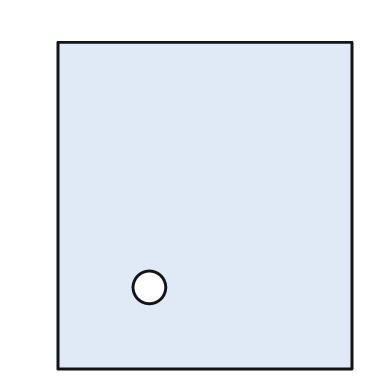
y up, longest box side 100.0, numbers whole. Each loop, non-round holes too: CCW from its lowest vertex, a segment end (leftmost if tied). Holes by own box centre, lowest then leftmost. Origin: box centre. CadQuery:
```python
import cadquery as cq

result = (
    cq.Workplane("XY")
    .moveTo(-45.0, -50.0)
    .lineTo(45.0, -50.0)
    .lineTo(45.0, 50.0)
    .lineTo(-45.0, 50.0)
    .close()
    .moveTo(-17.0, -25.0)
    .circle(5.0)
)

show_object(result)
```